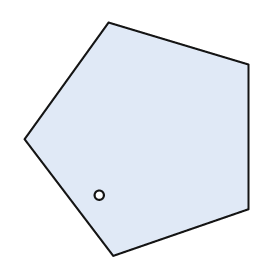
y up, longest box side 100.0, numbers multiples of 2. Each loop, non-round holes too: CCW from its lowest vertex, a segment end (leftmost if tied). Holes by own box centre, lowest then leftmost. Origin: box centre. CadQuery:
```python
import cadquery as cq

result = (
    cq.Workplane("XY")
    .moveTo(-10.0, -50.0)
    .lineTo(48.0, -30.0)
    .lineTo(48.0, 32.0)
    .lineTo(-12.0, 50.0)
    .lineTo(-48.0, 0.0)
    .close()
    .moveTo(-16.0, -24.0)
    .circle(2.0)
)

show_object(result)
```